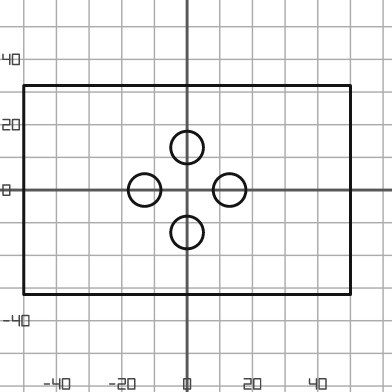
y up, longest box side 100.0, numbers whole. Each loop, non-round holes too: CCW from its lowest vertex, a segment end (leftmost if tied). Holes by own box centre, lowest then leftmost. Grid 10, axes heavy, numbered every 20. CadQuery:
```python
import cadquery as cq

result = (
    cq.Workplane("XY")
    .moveTo(-50.0, -32.0)
    .lineTo(50.0, -32.0)
    .lineTo(50.0, 32.0)
    .lineTo(-50.0, 32.0)
    .close()
    .moveTo(0.0, -13.0)
    .circle(5.0)
    .moveTo(-13.0, 0.0)
    .circle(5.0)
    .moveTo(13.0, 0.0)
    .circle(5.0)
    .moveTo(0.0, 13.0)
    .circle(5.0)
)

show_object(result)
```